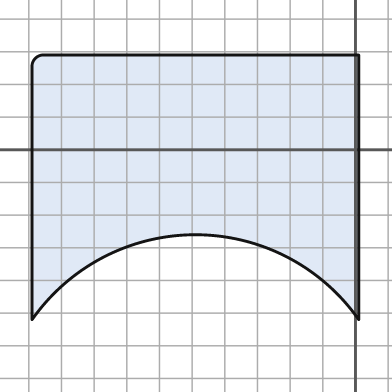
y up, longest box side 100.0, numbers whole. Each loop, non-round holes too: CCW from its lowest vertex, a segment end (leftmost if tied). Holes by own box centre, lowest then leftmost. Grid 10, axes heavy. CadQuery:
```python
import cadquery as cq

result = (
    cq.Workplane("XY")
    .moveTo(-99.0, -52.0)
    .threePointArc((-49.0, -26.0), (1.0, -52.0))
    .lineTo(1.0, 29.0)
    .lineTo(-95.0, 29.0)
    .threePointArc((-98.0, 28.0), (-99.0, 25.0))
    .close()
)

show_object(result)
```